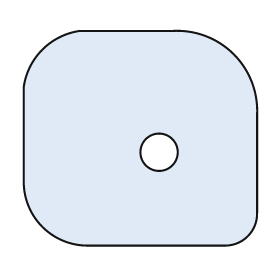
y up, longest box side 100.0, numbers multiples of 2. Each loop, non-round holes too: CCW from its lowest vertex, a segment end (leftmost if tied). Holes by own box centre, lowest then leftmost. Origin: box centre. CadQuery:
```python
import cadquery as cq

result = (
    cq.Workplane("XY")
    .moveTo(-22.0, -46.0)
    .lineTo(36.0, -46.0)
    .threePointArc((46.0, -42.0), (50.0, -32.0))
    .lineTo(50.0, 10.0)
    .threePointArc((40.0, 36.0), (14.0, 46.0))
    .lineTo(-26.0, 46.0)
    .threePointArc((-42.0, 38.0), (-50.0, 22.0))
    .lineTo(-50.0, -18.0)
    .threePointArc((-42.0, -38.0), (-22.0, -46.0))
    .close()
    .moveTo(8.0, -6.0)
    .circle(8.0)
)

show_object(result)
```